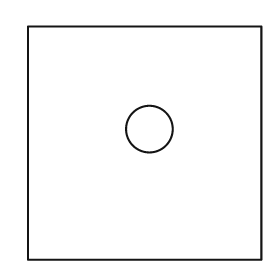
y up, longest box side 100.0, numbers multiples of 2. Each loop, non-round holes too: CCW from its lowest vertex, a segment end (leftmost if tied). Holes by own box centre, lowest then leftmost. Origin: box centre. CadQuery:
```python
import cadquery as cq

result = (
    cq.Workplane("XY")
    .moveTo(-50.0, -50.0)
    .lineTo(50.0, -50.0)
    .lineTo(50.0, 50.0)
    .lineTo(-50.0, 50.0)
    .close()
    .moveTo(2.0, 6.0)
    .circle(10.0)
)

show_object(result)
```